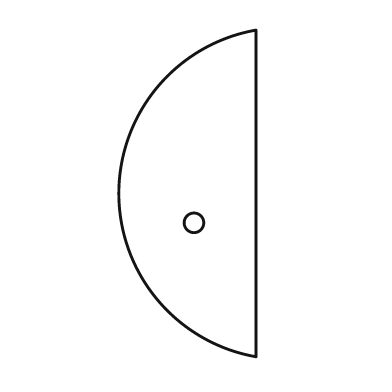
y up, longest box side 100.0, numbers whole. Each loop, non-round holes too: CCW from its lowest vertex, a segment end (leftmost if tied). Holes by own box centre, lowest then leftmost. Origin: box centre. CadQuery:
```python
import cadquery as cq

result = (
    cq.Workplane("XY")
    .moveTo(21.0, -50.0)
    .lineTo(21.0, 50.0)
    .threePointArc((-21.0, 0.0), (21.0, -50.0))
    .close()
    .moveTo(2.0, -9.0)
    .circle(3.0)
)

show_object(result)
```